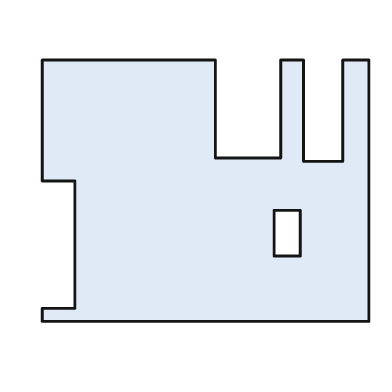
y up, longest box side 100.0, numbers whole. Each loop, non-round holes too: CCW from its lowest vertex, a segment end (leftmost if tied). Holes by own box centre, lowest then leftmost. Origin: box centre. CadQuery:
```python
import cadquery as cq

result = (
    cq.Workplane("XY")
    .moveTo(-50.0, -40.0)
    .lineTo(50.0, -40.0)
    .lineTo(50.0, 40.0)
    .lineTo(42.0, 40.0)
    .lineTo(42.0, 9.0)
    .lineTo(30.0, 9.0)
    .lineTo(30.0, 40.0)
    .lineTo(23.0, 40.0)
    .lineTo(23.0, 10.0)
    .lineTo(3.0, 10.0)
    .lineTo(3.0, 40.0)
    .lineTo(-50.0, 40.0)
    .lineTo(-50.0, 3.0)
    .lineTo(-40.0, 3.0)
    .lineTo(-40.0, -36.0)
    .lineTo(-50.0, -36.0)
    .close()
    .moveTo(21.0, -20.0)
    .lineTo(29.0, -20.0)
    .lineTo(29.0, -6.0)
    .lineTo(21.0, -6.0)
    .close()
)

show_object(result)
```